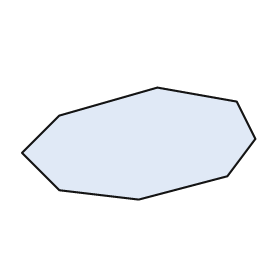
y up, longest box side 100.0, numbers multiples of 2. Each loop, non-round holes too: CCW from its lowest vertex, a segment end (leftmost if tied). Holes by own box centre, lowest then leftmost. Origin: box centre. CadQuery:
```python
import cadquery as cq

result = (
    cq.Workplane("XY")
    .moveTo(0.0, -24.0)
    .lineTo(38.0, -14.0)
    .lineTo(50.0, 2.0)
    .lineTo(42.0, 18.0)
    .lineTo(8.0, 24.0)
    .lineTo(-34.0, 12.0)
    .lineTo(-50.0, -4.0)
    .lineTo(-34.0, -20.0)
    .close()
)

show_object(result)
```